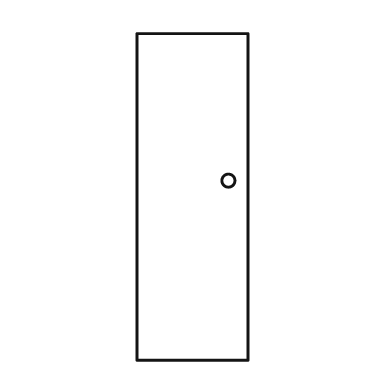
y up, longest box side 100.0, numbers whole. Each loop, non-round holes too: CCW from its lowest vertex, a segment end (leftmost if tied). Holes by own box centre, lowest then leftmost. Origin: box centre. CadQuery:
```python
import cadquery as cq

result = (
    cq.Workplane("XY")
    .moveTo(-17.0, -50.0)
    .lineTo(17.0, -50.0)
    .lineTo(17.0, 50.0)
    .lineTo(-17.0, 50.0)
    .close()
    .moveTo(11.0, 5.0)
    .circle(2.0)
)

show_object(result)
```